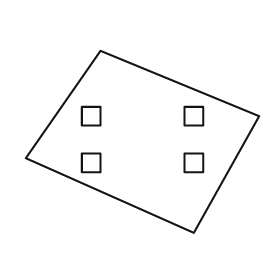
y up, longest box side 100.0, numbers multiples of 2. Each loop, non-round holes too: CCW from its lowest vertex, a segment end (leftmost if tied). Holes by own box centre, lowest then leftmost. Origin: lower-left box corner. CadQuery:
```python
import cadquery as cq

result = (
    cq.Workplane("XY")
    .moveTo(72.0, 0.0)
    .lineTo(100.0, 50.0)
    .lineTo(32.0, 78.0)
    .lineTo(0.0, 32.0)
    .close()
    .moveTo(24.0, 26.0)
    .lineTo(32.0, 26.0)
    .lineTo(32.0, 34.0)
    .lineTo(24.0, 34.0)
    .close()
    .moveTo(68.0, 26.0)
    .lineTo(76.0, 26.0)
    .lineTo(76.0, 34.0)
    .lineTo(68.0, 34.0)
    .close()
    .moveTo(24.0, 46.0)
    .lineTo(32.0, 46.0)
    .lineTo(32.0, 54.0)
    .lineTo(24.0, 54.0)
    .close()
    .moveTo(68.0, 46.0)
    .lineTo(76.0, 46.0)
    .lineTo(76.0, 54.0)
    .lineTo(68.0, 54.0)
    .close()
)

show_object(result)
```